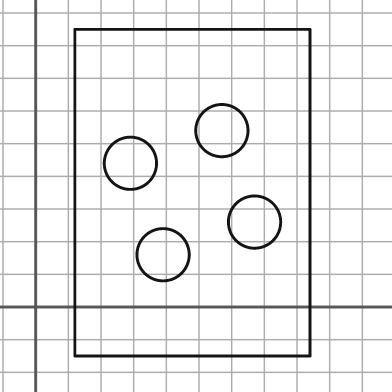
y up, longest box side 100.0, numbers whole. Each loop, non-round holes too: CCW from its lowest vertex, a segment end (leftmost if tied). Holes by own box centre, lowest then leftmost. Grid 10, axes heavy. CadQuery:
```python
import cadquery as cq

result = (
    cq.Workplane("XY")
    .moveTo(12.0, -15.0)
    .lineTo(84.0, -15.0)
    .lineTo(84.0, 85.0)
    .lineTo(12.0, 85.0)
    .close()
    .moveTo(39.0, 16.0)
    .circle(8.0)
    .moveTo(67.0, 26.0)
    .circle(8.0)
    .moveTo(29.0, 44.0)
    .circle(8.0)
    .moveTo(57.0, 54.0)
    .circle(8.0)
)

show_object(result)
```